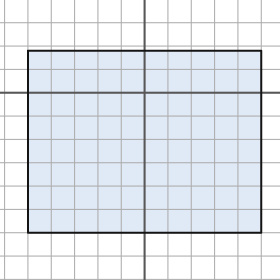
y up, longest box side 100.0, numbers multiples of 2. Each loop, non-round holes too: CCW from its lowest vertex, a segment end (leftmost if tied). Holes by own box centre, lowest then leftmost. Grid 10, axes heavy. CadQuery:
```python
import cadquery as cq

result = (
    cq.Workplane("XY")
    .moveTo(-50.0, -60.0)
    .lineTo(50.0, -60.0)
    .lineTo(50.0, 18.0)
    .lineTo(-50.0, 18.0)
    .close()
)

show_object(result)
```